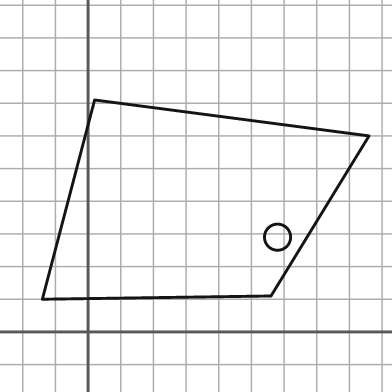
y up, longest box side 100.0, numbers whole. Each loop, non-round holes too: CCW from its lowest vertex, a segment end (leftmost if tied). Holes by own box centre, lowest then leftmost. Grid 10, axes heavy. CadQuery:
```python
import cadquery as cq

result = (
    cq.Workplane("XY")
    .moveTo(-14.0, 10.0)
    .lineTo(56.0, 11.0)
    .lineTo(86.0, 60.0)
    .lineTo(2.0, 71.0)
    .close()
    .moveTo(58.0, 29.0)
    .circle(4.0)
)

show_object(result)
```